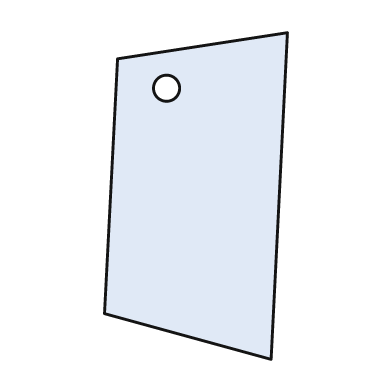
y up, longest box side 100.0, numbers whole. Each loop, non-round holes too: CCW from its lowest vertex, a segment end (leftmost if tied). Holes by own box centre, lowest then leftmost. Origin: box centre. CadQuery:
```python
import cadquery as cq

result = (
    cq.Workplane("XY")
    .moveTo(23.0, -50.0)
    .lineTo(28.0, 50.0)
    .lineTo(-24.0, 42.0)
    .lineTo(-28.0, -36.0)
    .close()
    .moveTo(-9.0, 33.0)
    .circle(4.0)
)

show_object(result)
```